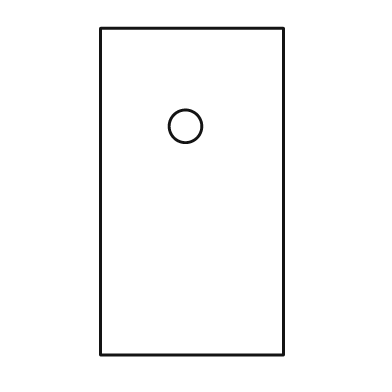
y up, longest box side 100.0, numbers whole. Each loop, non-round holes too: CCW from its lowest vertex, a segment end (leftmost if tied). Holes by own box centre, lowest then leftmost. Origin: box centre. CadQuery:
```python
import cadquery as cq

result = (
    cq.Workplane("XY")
    .moveTo(-28.0, -50.0)
    .lineTo(28.0, -50.0)
    .lineTo(28.0, 50.0)
    .lineTo(-28.0, 50.0)
    .close()
    .moveTo(-2.0, 20.0)
    .circle(5.0)
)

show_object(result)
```